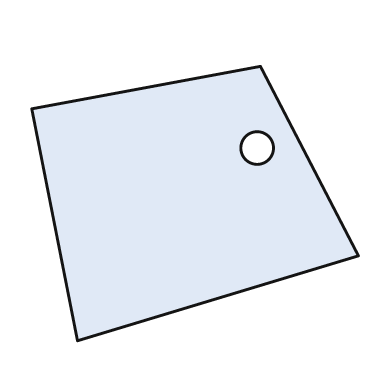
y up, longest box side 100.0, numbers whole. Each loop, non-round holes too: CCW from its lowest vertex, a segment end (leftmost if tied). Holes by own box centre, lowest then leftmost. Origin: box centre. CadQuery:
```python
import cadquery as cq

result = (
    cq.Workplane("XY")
    .moveTo(-36.0, -42.0)
    .lineTo(50.0, -16.0)
    .lineTo(20.0, 42.0)
    .lineTo(-50.0, 29.0)
    .close()
    .moveTo(19.0, 17.0)
    .circle(5.0)
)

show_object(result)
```